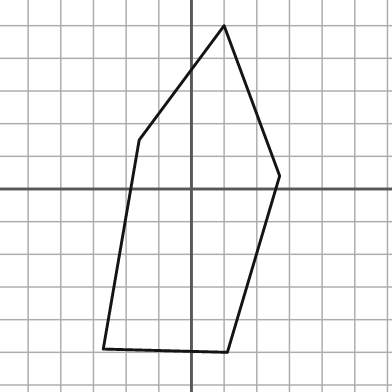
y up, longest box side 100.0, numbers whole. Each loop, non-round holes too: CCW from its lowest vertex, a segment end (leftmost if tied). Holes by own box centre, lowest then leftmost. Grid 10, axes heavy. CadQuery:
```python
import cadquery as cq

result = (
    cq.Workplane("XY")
    .moveTo(11.0, -50.0)
    .lineTo(27.0, 4.0)
    .lineTo(10.0, 50.0)
    .lineTo(-16.0, 15.0)
    .lineTo(-27.0, -49.0)
    .close()
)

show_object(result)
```